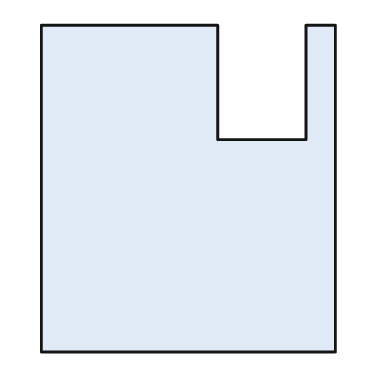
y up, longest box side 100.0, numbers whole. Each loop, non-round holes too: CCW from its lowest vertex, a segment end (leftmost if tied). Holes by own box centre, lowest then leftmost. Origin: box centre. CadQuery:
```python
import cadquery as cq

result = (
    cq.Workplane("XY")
    .moveTo(-45.0, -50.0)
    .lineTo(45.0, -50.0)
    .lineTo(45.0, 50.0)
    .lineTo(36.0, 50.0)
    .lineTo(36.0, 15.0)
    .lineTo(9.0, 15.0)
    .lineTo(9.0, 50.0)
    .lineTo(-45.0, 50.0)
    .close()
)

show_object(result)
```